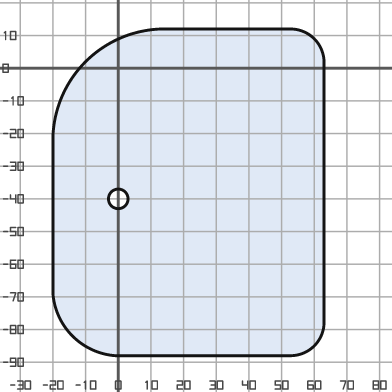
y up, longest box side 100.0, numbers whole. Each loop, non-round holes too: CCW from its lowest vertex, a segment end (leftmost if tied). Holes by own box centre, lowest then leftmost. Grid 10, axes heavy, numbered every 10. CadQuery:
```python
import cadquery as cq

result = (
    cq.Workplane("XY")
    .moveTo(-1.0, -88.0)
    .lineTo(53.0, -88.0)
    .threePointArc((60.0, -85.0), (63.0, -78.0))
    .lineTo(63.0, 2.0)
    .threePointArc((60.0, 9.0), (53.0, 12.0))
    .lineTo(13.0, 12.0)
    .threePointArc((-10.0, 2.0), (-20.0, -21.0))
    .lineTo(-20.0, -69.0)
    .threePointArc((-14.0, -82.0), (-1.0, -88.0))
    .close()
    .moveTo(0.0, -40.0)
    .circle(3.0)
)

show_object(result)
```